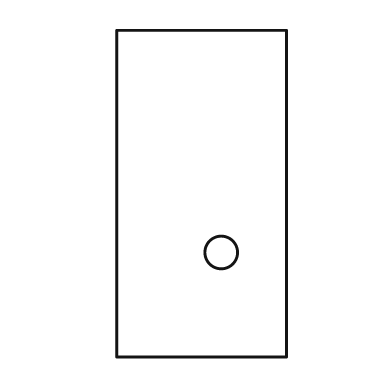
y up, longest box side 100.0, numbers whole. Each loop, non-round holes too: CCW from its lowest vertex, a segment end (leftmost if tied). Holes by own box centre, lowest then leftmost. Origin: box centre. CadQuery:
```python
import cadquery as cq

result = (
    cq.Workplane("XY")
    .moveTo(-26.0, -50.0)
    .lineTo(26.0, -50.0)
    .lineTo(26.0, 50.0)
    .lineTo(-26.0, 50.0)
    .close()
    .moveTo(6.0, -18.0)
    .circle(5.0)
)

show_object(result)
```